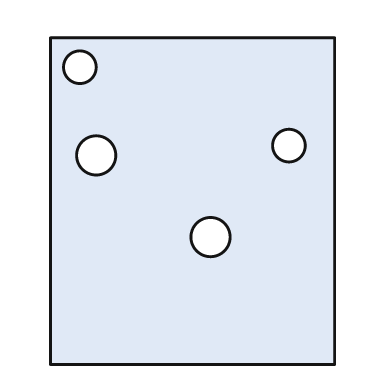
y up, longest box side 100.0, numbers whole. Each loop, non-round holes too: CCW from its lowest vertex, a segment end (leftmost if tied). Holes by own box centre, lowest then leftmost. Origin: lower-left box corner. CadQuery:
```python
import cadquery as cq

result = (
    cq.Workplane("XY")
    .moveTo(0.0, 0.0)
    .lineTo(87.0, 0.0)
    .lineTo(87.0, 100.0)
    .lineTo(0.0, 100.0)
    .close()
    .moveTo(49.0, 39.0)
    .circle(6.0)
    .moveTo(14.0, 64.0)
    .circle(6.0)
    .moveTo(73.0, 67.0)
    .circle(5.0)
    .moveTo(9.0, 91.0)
    .circle(5.0)
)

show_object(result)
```